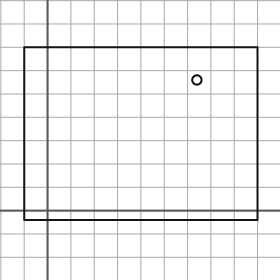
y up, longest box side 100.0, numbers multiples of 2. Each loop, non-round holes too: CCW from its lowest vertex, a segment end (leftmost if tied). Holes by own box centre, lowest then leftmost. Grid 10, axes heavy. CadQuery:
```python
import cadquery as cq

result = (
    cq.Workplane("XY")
    .moveTo(-10.0, -4.0)
    .lineTo(90.0, -4.0)
    .lineTo(90.0, 70.0)
    .lineTo(-10.0, 70.0)
    .close()
    .moveTo(64.0, 56.0)
    .circle(2.0)
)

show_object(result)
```